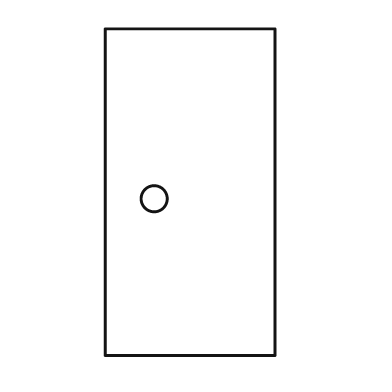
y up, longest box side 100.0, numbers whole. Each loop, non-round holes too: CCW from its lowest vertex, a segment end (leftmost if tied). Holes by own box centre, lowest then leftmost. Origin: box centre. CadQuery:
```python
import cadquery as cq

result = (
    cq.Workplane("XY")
    .moveTo(-26.0, -50.0)
    .lineTo(26.0, -50.0)
    .lineTo(26.0, 50.0)
    .lineTo(-26.0, 50.0)
    .close()
    .moveTo(-11.0, -2.0)
    .circle(4.0)
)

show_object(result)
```